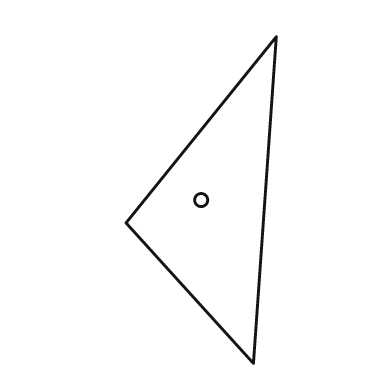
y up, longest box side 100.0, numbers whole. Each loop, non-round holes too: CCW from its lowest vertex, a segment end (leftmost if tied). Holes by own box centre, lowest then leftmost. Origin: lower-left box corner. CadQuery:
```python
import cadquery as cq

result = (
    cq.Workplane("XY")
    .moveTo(39.0, 0.0)
    .lineTo(46.0, 100.0)
    .lineTo(0.0, 43.0)
    .close()
    .moveTo(23.0, 50.0)
    .circle(2.0)
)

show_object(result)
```